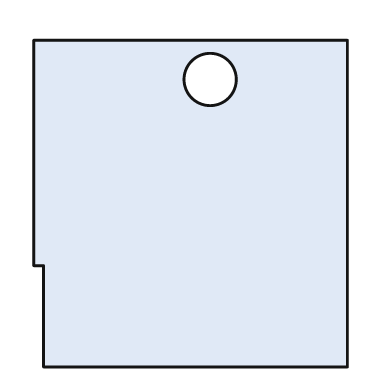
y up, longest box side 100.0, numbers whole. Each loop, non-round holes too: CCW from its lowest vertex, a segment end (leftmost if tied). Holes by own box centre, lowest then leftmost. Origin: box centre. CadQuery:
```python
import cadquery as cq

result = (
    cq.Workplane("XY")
    .moveTo(-45.0, -50.0)
    .lineTo(48.0, -50.0)
    .lineTo(48.0, 50.0)
    .lineTo(-48.0, 50.0)
    .lineTo(-48.0, -19.0)
    .lineTo(-45.0, -19.0)
    .close()
    .moveTo(6.0, 38.0)
    .circle(8.0)
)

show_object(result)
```